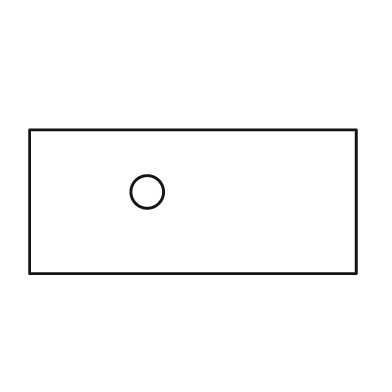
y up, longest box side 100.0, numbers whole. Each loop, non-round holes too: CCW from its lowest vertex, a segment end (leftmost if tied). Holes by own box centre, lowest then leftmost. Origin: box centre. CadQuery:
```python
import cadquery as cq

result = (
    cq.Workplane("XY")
    .moveTo(-50.0, -22.0)
    .lineTo(50.0, -22.0)
    .lineTo(50.0, 22.0)
    .lineTo(-50.0, 22.0)
    .close()
    .moveTo(-14.0, 3.0)
    .circle(5.0)
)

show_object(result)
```